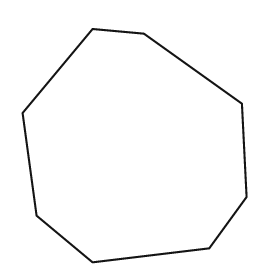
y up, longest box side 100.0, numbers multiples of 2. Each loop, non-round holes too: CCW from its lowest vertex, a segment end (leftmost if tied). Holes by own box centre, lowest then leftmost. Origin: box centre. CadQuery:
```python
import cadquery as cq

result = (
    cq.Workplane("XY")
    .moveTo(-18.0, -50.0)
    .lineTo(32.0, -44.0)
    .lineTo(48.0, -22.0)
    .lineTo(46.0, 18.0)
    .lineTo(4.0, 48.0)
    .lineTo(-18.0, 50.0)
    .lineTo(-48.0, 14.0)
    .lineTo(-42.0, -30.0)
    .close()
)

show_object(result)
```